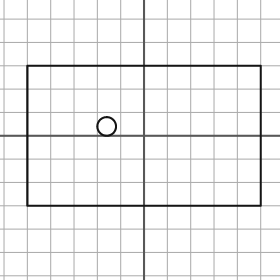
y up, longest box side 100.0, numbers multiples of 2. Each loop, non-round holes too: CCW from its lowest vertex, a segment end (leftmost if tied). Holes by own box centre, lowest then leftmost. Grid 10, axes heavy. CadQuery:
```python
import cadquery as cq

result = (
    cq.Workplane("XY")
    .moveTo(-50.0, -30.0)
    .lineTo(50.0, -30.0)
    .lineTo(50.0, 30.0)
    .lineTo(-50.0, 30.0)
    .close()
    .moveTo(-16.0, 4.0)
    .circle(4.0)
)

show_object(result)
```